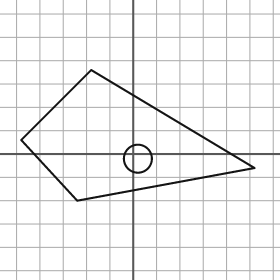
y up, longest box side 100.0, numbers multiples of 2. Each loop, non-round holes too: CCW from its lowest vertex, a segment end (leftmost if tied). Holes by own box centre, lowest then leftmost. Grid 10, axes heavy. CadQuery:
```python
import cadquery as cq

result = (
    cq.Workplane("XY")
    .moveTo(-24.0, -20.0)
    .lineTo(52.0, -6.0)
    .lineTo(-18.0, 36.0)
    .lineTo(-48.0, 6.0)
    .close()
    .moveTo(2.0, -2.0)
    .circle(6.0)
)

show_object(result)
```